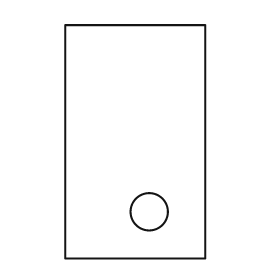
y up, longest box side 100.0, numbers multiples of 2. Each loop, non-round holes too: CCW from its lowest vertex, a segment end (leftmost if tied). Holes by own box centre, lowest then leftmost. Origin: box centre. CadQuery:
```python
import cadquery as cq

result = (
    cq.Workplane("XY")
    .moveTo(-30.0, -50.0)
    .lineTo(30.0, -50.0)
    .lineTo(30.0, 50.0)
    .lineTo(-30.0, 50.0)
    .close()
    .moveTo(6.0, -30.0)
    .circle(8.0)
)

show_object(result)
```